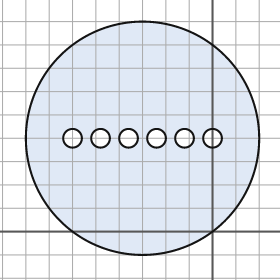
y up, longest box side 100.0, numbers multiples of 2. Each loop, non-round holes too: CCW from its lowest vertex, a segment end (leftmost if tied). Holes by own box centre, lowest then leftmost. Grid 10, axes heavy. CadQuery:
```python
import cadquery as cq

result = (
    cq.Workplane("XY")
    .moveTo(-30.0, 40.0)
    .circle(50.0)
    .moveTo(-60.0, 40.0)
    .circle(4.0)
    .moveTo(-48.0, 40.0)
    .circle(4.0)
    .moveTo(-36.0, 40.0)
    .circle(4.0)
    .moveTo(-24.0, 40.0)
    .circle(4.0)
    .moveTo(-12.0, 40.0)
    .circle(4.0)
    .moveTo(0.0, 40.0)
    .circle(4.0)
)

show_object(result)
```